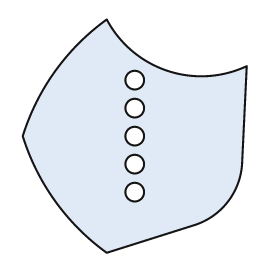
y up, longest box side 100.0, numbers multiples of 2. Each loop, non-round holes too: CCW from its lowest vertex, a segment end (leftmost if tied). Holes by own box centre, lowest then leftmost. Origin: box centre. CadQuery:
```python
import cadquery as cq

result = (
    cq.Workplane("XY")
    .moveTo(-12.0, -50.0)
    .lineTo(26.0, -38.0)
    .threePointArc((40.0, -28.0), (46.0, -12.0))
    .lineTo(48.0, 30.0)
    .threePointArc((14.0, 28.0), (-12.0, 50.0))
    .threePointArc((-34.0, 28.0), (-48.0, 0.0))
    .threePointArc((-34.0, -28.0), (-12.0, -50.0))
    .close()
    .moveTo(0.0, -24.0)
    .circle(4.0)
    .moveTo(0.0, -12.0)
    .circle(4.0)
    .moveTo(0.0, 0.0)
    .circle(4.0)
    .moveTo(0.0, 12.0)
    .circle(4.0)
    .moveTo(0.0, 24.0)
    .circle(4.0)
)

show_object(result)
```